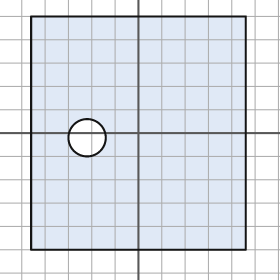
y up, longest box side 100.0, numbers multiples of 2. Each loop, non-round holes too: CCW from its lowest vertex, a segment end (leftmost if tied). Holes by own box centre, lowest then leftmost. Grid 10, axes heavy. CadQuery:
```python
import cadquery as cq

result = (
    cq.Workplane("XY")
    .moveTo(-46.0, -50.0)
    .lineTo(46.0, -50.0)
    .lineTo(46.0, 50.0)
    .lineTo(-46.0, 50.0)
    .close()
    .moveTo(-22.0, -2.0)
    .circle(8.0)
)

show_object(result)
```